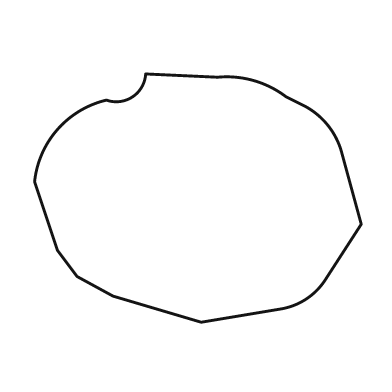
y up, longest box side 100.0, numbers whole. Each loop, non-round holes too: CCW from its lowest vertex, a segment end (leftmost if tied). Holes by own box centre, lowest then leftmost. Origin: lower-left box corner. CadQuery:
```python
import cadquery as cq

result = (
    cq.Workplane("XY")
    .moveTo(51.0, 0.0)
    .lineTo(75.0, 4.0)
    .threePointArc((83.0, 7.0), (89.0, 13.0))
    .lineTo(100.0, 30.0)
    .lineTo(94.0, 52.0)
    .threePointArc((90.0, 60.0), (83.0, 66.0))
    .lineTo(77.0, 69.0)
    .threePointArc((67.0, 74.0), (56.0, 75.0))
    .lineTo(34.0, 76.0)
    .threePointArc((30.0, 69.0), (22.0, 68.0))
    .threePointArc((7.0, 59.0), (0.0, 43.0))
    .lineTo(7.0, 22.0)
    .lineTo(13.0, 14.0)
    .lineTo(24.0, 8.0)
    .close()
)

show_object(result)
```